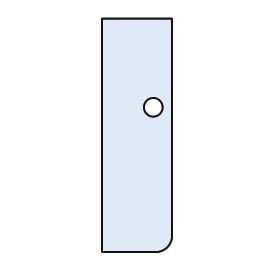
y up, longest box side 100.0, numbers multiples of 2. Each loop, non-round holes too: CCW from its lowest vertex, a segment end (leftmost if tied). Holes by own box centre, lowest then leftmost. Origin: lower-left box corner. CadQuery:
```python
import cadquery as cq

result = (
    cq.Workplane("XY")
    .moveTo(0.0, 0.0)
    .lineTo(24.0, 0.0)
    .threePointArc((28.0, 2.0), (30.0, 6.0))
    .lineTo(30.0, 100.0)
    .lineTo(0.0, 100.0)
    .close()
    .moveTo(22.0, 62.0)
    .circle(4.0)
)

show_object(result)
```